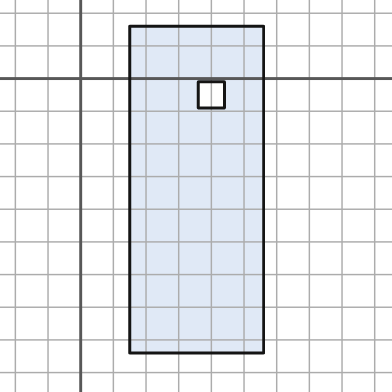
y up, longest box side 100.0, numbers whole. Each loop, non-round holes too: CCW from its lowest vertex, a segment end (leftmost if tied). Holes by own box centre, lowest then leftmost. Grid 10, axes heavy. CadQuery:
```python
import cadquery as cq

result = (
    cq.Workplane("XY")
    .moveTo(15.0, -84.0)
    .lineTo(56.0, -84.0)
    .lineTo(56.0, 16.0)
    .lineTo(15.0, 16.0)
    .close()
    .moveTo(36.0, -9.0)
    .lineTo(44.0, -9.0)
    .lineTo(44.0, -1.0)
    .lineTo(36.0, -1.0)
    .close()
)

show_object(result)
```